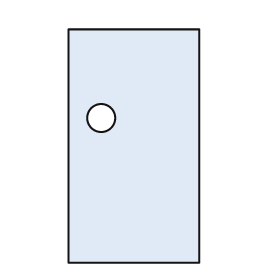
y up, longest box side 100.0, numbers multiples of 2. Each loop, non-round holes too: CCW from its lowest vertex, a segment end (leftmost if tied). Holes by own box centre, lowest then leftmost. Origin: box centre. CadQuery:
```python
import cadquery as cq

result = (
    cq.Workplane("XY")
    .moveTo(-28.0, -50.0)
    .lineTo(28.0, -50.0)
    .lineTo(28.0, 50.0)
    .lineTo(-28.0, 50.0)
    .close()
    .moveTo(-14.0, 12.0)
    .circle(6.0)
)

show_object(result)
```